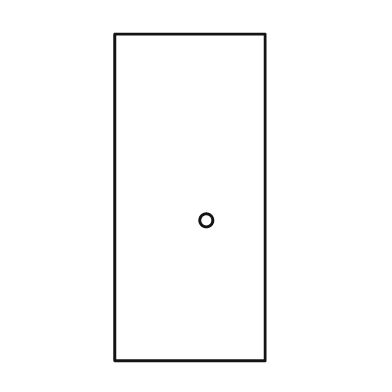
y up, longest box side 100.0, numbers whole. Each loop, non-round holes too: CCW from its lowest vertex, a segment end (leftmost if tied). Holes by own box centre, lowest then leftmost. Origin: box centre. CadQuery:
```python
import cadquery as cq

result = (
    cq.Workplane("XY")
    .moveTo(-23.0, -50.0)
    .lineTo(23.0, -50.0)
    .lineTo(23.0, 50.0)
    .lineTo(-23.0, 50.0)
    .close()
    .moveTo(5.0, -7.0)
    .circle(2.0)
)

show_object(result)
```